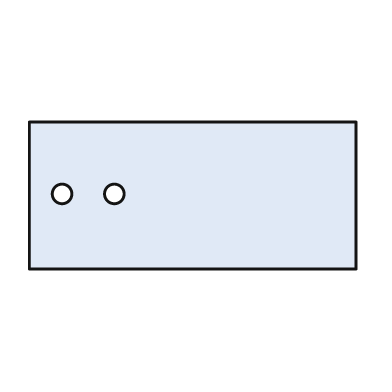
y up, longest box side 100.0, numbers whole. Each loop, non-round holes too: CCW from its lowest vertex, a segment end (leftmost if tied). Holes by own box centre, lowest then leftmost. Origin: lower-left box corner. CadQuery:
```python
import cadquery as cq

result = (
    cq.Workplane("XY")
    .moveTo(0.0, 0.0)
    .lineTo(100.0, 0.0)
    .lineTo(100.0, 45.0)
    .lineTo(0.0, 45.0)
    .close()
    .moveTo(10.0, 23.0)
    .circle(3.0)
    .moveTo(26.0, 23.0)
    .circle(3.0)
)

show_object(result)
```